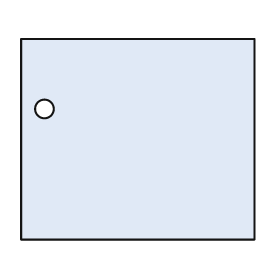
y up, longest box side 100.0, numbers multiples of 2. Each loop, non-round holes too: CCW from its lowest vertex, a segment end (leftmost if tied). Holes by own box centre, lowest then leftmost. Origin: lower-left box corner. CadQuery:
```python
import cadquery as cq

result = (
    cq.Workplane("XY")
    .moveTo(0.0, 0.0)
    .lineTo(100.0, 0.0)
    .lineTo(100.0, 86.0)
    .lineTo(0.0, 86.0)
    .close()
    .moveTo(10.0, 56.0)
    .circle(4.0)
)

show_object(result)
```